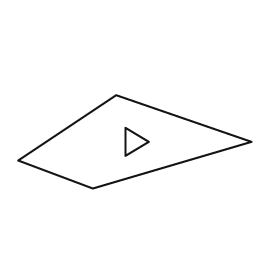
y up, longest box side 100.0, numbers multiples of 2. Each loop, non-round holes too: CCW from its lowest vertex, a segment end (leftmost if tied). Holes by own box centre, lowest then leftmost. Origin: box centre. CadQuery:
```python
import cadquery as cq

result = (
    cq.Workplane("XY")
    .moveTo(-18.0, -20.0)
    .lineTo(50.0, 0.0)
    .lineTo(-8.0, 20.0)
    .lineTo(-50.0, -8.0)
    .close()
    .moveTo(-4.0, -6.0)
    .lineTo(6.0, 0.0)
    .lineTo(-4.0, 6.0)
    .close()
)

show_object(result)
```